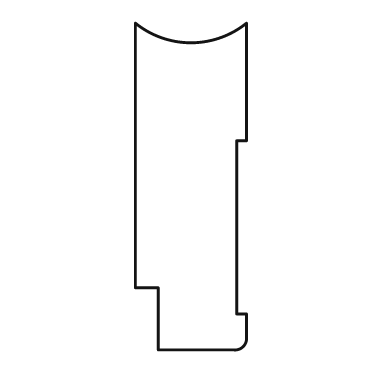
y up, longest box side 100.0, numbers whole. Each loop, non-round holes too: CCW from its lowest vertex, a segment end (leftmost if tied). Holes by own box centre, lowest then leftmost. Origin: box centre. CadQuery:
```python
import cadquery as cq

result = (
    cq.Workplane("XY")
    .moveTo(-10.0, -50.0)
    .lineTo(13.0, -50.0)
    .threePointArc((16.0, -49.0), (17.0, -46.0))
    .lineTo(17.0, -39.0)
    .lineTo(14.0, -39.0)
    .lineTo(14.0, 14.0)
    .lineTo(17.0, 14.0)
    .lineTo(17.0, 50.0)
    .threePointArc((0.0, 44.0), (-17.0, 50.0))
    .lineTo(-17.0, -31.0)
    .lineTo(-10.0, -31.0)
    .close()
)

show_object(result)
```